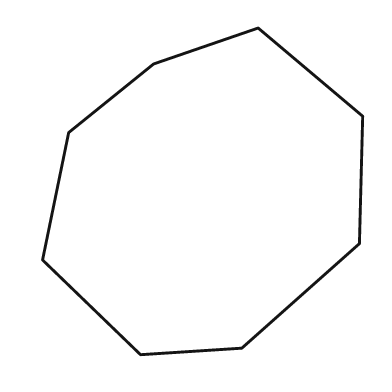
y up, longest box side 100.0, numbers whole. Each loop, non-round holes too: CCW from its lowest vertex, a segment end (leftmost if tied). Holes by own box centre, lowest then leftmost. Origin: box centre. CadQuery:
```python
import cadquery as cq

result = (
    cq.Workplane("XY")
    .moveTo(-19.0, -50.0)
    .lineTo(12.0, -48.0)
    .lineTo(48.0, -16.0)
    .lineTo(49.0, 23.0)
    .lineTo(17.0, 50.0)
    .lineTo(-15.0, 39.0)
    .lineTo(-41.0, 18.0)
    .lineTo(-49.0, -21.0)
    .close()
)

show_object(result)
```